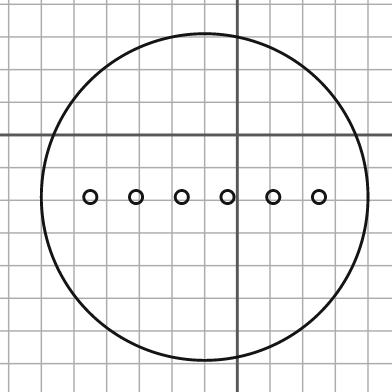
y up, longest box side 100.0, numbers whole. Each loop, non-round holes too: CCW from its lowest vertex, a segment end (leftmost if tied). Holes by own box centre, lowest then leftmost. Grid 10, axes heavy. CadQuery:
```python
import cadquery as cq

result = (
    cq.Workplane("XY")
    .moveTo(-10.0, -19.0)
    .circle(50.0)
    .moveTo(-45.0, -19.0)
    .circle(2.0)
    .moveTo(-31.0, -19.0)
    .circle(2.0)
    .moveTo(-17.0, -19.0)
    .circle(2.0)
    .moveTo(-3.0, -19.0)
    .circle(2.0)
    .moveTo(11.0, -19.0)
    .circle(2.0)
    .moveTo(25.0, -19.0)
    .circle(2.0)
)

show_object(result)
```